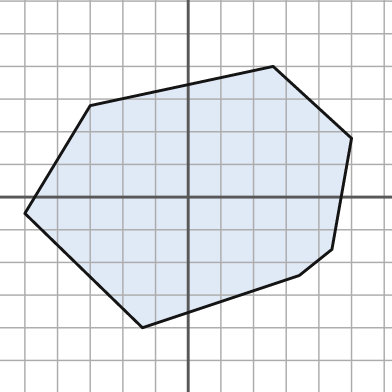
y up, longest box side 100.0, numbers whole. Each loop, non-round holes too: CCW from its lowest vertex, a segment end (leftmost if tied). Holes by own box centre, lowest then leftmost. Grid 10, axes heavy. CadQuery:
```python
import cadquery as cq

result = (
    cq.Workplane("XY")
    .moveTo(-14.0, -40.0)
    .lineTo(34.0, -24.0)
    .lineTo(44.0, -16.0)
    .lineTo(50.0, 18.0)
    .lineTo(26.0, 40.0)
    .lineTo(-30.0, 28.0)
    .lineTo(-50.0, -5.0)
    .close()
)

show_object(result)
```